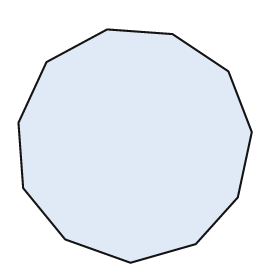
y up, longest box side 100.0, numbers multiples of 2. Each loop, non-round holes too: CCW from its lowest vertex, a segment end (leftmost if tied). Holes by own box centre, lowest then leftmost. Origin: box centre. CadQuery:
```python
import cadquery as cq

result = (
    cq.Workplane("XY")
    .moveTo(-2.0, -50.0)
    .lineTo(26.0, -42.0)
    .lineTo(44.0, -22.0)
    .lineTo(50.0, 6.0)
    .lineTo(40.0, 32.0)
    .lineTo(16.0, 48.0)
    .lineTo(-12.0, 50.0)
    .lineTo(-38.0, 36.0)
    .lineTo(-50.0, 10.0)
    .lineTo(-48.0, -18.0)
    .lineTo(-30.0, -40.0)
    .close()
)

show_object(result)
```